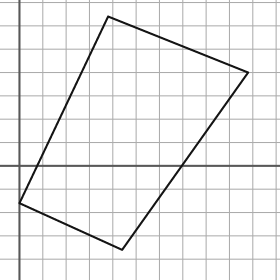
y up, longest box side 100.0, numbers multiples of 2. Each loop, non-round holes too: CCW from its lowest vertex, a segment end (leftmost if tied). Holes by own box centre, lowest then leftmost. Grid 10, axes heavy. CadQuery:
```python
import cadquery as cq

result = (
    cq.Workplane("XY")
    .moveTo(44.0, -36.0)
    .lineTo(98.0, 40.0)
    .lineTo(38.0, 64.0)
    .lineTo(0.0, -16.0)
    .close()
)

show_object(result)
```